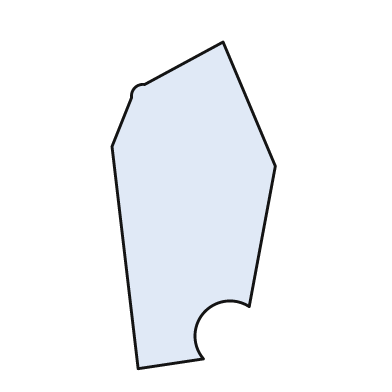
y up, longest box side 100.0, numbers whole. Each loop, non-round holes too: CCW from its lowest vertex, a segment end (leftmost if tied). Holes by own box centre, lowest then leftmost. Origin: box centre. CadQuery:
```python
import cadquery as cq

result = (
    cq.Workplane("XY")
    .moveTo(-17.0, -50.0)
    .lineTo(3.0, -47.0)
    .threePointArc((3.0, -33.0), (17.0, -31.0))
    .lineTo(25.0, 12.0)
    .lineTo(9.0, 50.0)
    .lineTo(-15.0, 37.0)
    .threePointArc((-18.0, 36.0), (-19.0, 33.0))
    .lineTo(-25.0, 18.0)
    .close()
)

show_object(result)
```